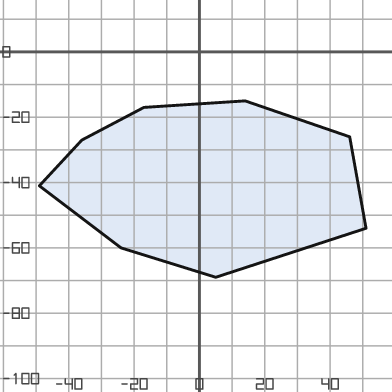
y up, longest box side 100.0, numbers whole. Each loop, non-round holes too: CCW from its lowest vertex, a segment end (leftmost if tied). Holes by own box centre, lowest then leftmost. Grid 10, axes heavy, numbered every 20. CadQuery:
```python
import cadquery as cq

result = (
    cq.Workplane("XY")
    .moveTo(5.0, -69.0)
    .lineTo(51.0, -54.0)
    .lineTo(46.0, -26.0)
    .lineTo(14.0, -15.0)
    .lineTo(-17.0, -17.0)
    .lineTo(-36.0, -27.0)
    .lineTo(-49.0, -41.0)
    .lineTo(-24.0, -60.0)
    .close()
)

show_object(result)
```